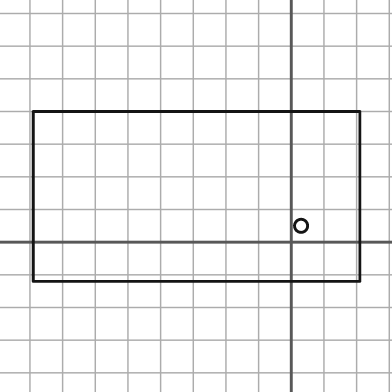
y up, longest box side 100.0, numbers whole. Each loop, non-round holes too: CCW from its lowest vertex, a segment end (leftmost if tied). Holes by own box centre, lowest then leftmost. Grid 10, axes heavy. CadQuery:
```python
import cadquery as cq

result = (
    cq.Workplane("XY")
    .moveTo(-79.0, -12.0)
    .lineTo(21.0, -12.0)
    .lineTo(21.0, 40.0)
    .lineTo(-79.0, 40.0)
    .close()
    .moveTo(3.0, 5.0)
    .circle(2.0)
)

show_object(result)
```